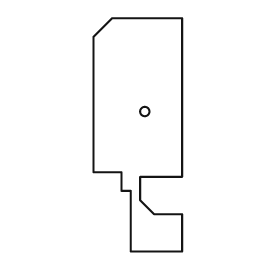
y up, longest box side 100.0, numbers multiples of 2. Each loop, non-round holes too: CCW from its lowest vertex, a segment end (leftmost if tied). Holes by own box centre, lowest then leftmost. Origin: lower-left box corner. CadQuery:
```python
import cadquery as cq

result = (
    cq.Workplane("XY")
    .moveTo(16.0, 0.0)
    .lineTo(38.0, 0.0)
    .lineTo(38.0, 16.0)
    .lineTo(26.0, 16.0)
    .lineTo(20.0, 22.0)
    .lineTo(20.0, 32.0)
    .lineTo(38.0, 32.0)
    .lineTo(38.0, 100.0)
    .lineTo(8.0, 100.0)
    .lineTo(0.0, 92.0)
    .lineTo(0.0, 34.0)
    .lineTo(12.0, 34.0)
    .lineTo(12.0, 26.0)
    .lineTo(16.0, 26.0)
    .close()
    .moveTo(22.0, 60.0)
    .circle(2.0)
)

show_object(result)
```